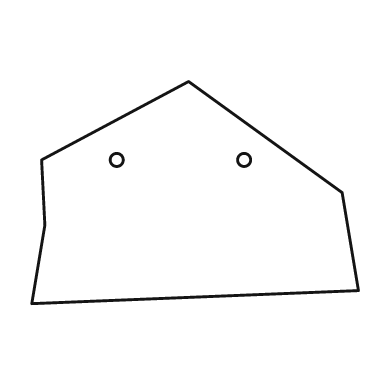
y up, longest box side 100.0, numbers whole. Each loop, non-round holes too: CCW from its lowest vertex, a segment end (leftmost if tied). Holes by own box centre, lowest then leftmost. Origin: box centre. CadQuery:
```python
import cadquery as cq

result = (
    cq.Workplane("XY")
    .moveTo(-50.0, -34.0)
    .lineTo(50.0, -30.0)
    .lineTo(45.0, 0.0)
    .lineTo(-2.0, 34.0)
    .lineTo(-47.0, 10.0)
    .lineTo(-46.0, -10.0)
    .close()
    .moveTo(-24.0, 10.0)
    .circle(2.0)
    .moveTo(15.0, 10.0)
    .circle(2.0)
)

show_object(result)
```